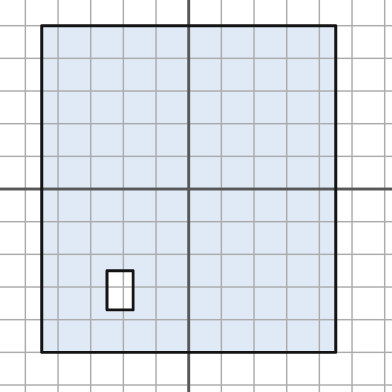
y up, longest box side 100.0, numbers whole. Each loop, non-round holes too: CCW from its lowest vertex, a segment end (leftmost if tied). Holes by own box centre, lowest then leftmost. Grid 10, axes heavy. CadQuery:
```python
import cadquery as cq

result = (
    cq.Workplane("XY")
    .moveTo(-45.0, -50.0)
    .lineTo(45.0, -50.0)
    .lineTo(45.0, 50.0)
    .lineTo(-45.0, 50.0)
    .close()
    .moveTo(-25.0, -37.0)
    .lineTo(-17.0, -37.0)
    .lineTo(-17.0, -25.0)
    .lineTo(-25.0, -25.0)
    .close()
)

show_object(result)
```